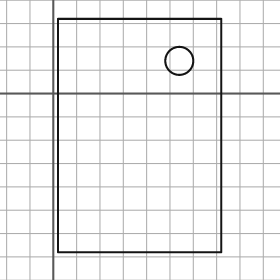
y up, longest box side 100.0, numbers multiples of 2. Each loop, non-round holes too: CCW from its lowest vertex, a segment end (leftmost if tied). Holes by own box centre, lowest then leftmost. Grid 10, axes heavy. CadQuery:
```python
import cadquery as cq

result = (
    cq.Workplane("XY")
    .moveTo(2.0, -68.0)
    .lineTo(72.0, -68.0)
    .lineTo(72.0, 32.0)
    .lineTo(2.0, 32.0)
    .close()
    .moveTo(54.0, 14.0)
    .circle(6.0)
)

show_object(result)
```